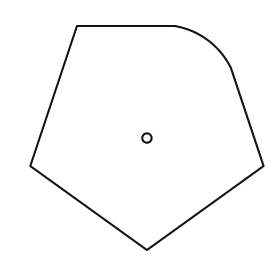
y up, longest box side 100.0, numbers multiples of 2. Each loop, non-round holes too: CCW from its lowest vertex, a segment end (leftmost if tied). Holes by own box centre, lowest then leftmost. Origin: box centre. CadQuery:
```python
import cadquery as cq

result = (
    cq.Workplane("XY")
    .moveTo(0.0, -48.0)
    .lineTo(50.0, -12.0)
    .lineTo(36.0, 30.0)
    .threePointArc((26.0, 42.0), (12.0, 48.0))
    .lineTo(-30.0, 48.0)
    .lineTo(-50.0, -12.0)
    .close()
    .moveTo(0.0, 0.0)
    .circle(2.0)
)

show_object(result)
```